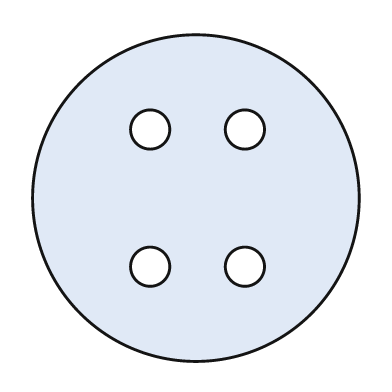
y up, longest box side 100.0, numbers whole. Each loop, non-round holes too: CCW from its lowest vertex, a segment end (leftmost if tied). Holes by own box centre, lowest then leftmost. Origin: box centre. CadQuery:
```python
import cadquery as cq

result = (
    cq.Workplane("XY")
    .moveTo(0.0, 0.0)
    .circle(50.0)
    .moveTo(-14.0, -21.0)
    .circle(6.0)
    .moveTo(15.0, -21.0)
    .circle(6.0)
    .moveTo(-14.0, 21.0)
    .circle(6.0)
    .moveTo(15.0, 21.0)
    .circle(6.0)
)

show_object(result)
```